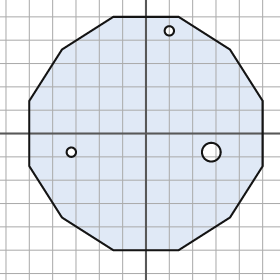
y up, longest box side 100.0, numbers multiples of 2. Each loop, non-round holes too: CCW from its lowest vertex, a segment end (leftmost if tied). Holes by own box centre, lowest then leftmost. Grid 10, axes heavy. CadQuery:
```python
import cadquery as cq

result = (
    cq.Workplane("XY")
    .moveTo(-14.0, -50.0)
    .lineTo(14.0, -50.0)
    .lineTo(36.0, -36.0)
    .lineTo(50.0, -14.0)
    .lineTo(50.0, 14.0)
    .lineTo(36.0, 36.0)
    .lineTo(14.0, 50.0)
    .lineTo(-14.0, 50.0)
    .lineTo(-36.0, 36.0)
    .lineTo(-50.0, 14.0)
    .lineTo(-50.0, -14.0)
    .lineTo(-36.0, -36.0)
    .close()
    .moveTo(-32.0, -8.0)
    .circle(2.0)
    .moveTo(28.0, -8.0)
    .circle(4.0)
    .moveTo(10.0, 44.0)
    .circle(2.0)
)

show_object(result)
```